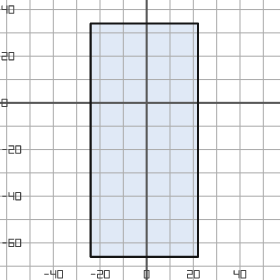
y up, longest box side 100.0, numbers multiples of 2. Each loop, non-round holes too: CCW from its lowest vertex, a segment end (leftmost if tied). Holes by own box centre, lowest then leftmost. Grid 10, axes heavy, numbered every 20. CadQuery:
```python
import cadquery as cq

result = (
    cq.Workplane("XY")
    .moveTo(-24.0, -66.0)
    .lineTo(22.0, -66.0)
    .lineTo(22.0, 34.0)
    .lineTo(-24.0, 34.0)
    .close()
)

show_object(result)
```